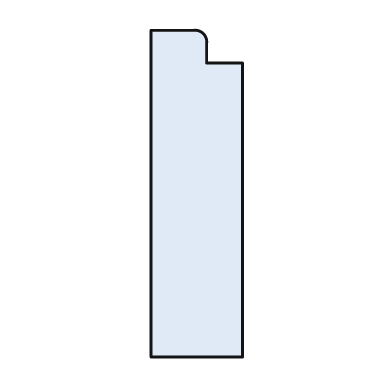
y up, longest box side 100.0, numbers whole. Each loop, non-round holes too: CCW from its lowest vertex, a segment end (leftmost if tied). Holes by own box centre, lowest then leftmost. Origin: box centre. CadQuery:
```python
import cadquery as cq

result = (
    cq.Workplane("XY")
    .moveTo(-14.0, -50.0)
    .lineTo(14.0, -50.0)
    .lineTo(14.0, 40.0)
    .lineTo(3.0, 40.0)
    .lineTo(3.0, 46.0)
    .threePointArc((2.0, 49.0), (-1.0, 50.0))
    .lineTo(-14.0, 50.0)
    .close()
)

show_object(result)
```